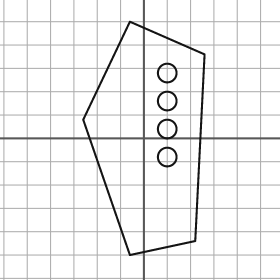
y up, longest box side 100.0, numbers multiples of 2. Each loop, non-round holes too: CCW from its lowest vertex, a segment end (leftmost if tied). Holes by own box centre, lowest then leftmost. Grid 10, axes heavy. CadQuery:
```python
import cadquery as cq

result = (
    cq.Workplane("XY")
    .moveTo(-6.0, -50.0)
    .lineTo(22.0, -44.0)
    .lineTo(26.0, 36.0)
    .lineTo(-6.0, 50.0)
    .lineTo(-26.0, 8.0)
    .close()
    .moveTo(10.0, -8.0)
    .circle(4.0)
    .moveTo(10.0, 4.0)
    .circle(4.0)
    .moveTo(10.0, 16.0)
    .circle(4.0)
    .moveTo(10.0, 28.0)
    .circle(4.0)
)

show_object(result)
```